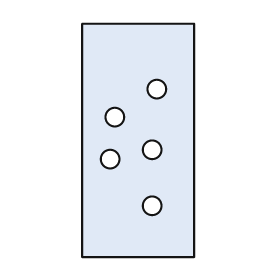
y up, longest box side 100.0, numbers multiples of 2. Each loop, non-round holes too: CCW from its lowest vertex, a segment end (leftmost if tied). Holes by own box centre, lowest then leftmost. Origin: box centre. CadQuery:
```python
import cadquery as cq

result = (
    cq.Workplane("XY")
    .moveTo(-24.0, -50.0)
    .lineTo(24.0, -50.0)
    .lineTo(24.0, 50.0)
    .lineTo(-24.0, 50.0)
    .close()
    .moveTo(6.0, -28.0)
    .circle(4.0)
    .moveTo(-12.0, -8.0)
    .circle(4.0)
    .moveTo(6.0, -4.0)
    .circle(4.0)
    .moveTo(-10.0, 10.0)
    .circle(4.0)
    .moveTo(8.0, 22.0)
    .circle(4.0)
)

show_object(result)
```